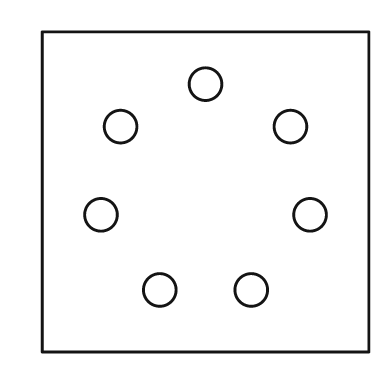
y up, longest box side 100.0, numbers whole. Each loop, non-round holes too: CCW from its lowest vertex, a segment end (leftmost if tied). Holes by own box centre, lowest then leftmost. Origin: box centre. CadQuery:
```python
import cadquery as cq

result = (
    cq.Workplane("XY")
    .moveTo(-50.0, -49.0)
    .lineTo(50.0, -49.0)
    .lineTo(50.0, 49.0)
    .lineTo(-50.0, 49.0)
    .close()
    .moveTo(-14.0, -30.0)
    .circle(5.0)
    .moveTo(14.0, -30.0)
    .circle(5.0)
    .moveTo(-32.0, -7.0)
    .circle(5.0)
    .moveTo(32.0, -7.0)
    .circle(5.0)
    .moveTo(-26.0, 20.0)
    .circle(5.0)
    .moveTo(26.0, 20.0)
    .circle(5.0)
    .moveTo(0.0, 33.0)
    .circle(5.0)
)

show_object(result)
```